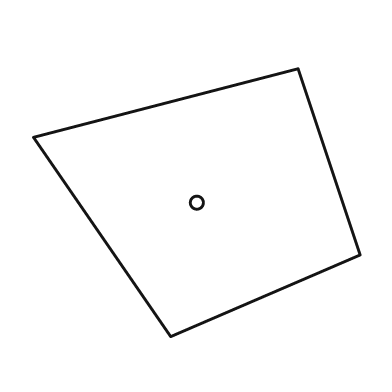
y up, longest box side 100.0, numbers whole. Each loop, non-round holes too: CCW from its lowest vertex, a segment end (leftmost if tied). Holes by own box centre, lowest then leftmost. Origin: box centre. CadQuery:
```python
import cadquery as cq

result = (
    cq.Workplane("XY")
    .moveTo(-8.0, -41.0)
    .lineTo(50.0, -16.0)
    .lineTo(31.0, 41.0)
    .lineTo(-50.0, 20.0)
    .close()
    .moveTo(0.0, 0.0)
    .circle(2.0)
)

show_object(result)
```